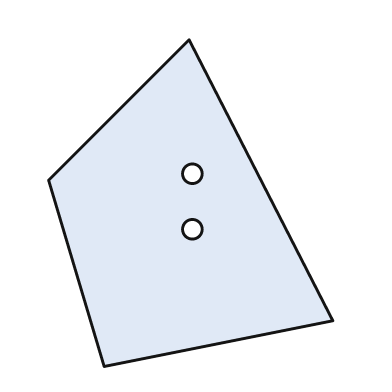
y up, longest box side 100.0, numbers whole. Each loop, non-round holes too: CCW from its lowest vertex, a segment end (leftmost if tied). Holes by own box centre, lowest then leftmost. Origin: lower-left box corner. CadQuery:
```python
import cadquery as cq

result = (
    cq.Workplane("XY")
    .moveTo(17.0, 0.0)
    .lineTo(87.0, 14.0)
    .lineTo(43.0, 100.0)
    .lineTo(0.0, 57.0)
    .close()
    .moveTo(44.0, 42.0)
    .circle(3.0)
    .moveTo(44.0, 59.0)
    .circle(3.0)
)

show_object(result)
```